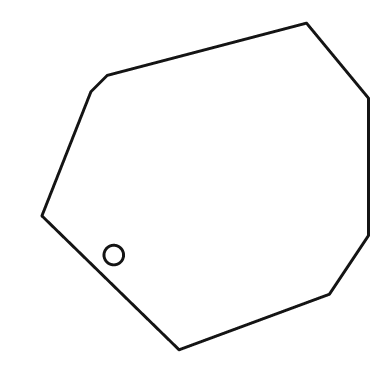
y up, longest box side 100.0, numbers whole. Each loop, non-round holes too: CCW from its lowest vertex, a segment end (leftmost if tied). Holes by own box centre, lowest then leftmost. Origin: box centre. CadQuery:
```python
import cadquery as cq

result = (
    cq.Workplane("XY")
    .moveTo(-8.0, -50.0)
    .lineTo(38.0, -33.0)
    .lineTo(50.0, -15.0)
    .lineTo(50.0, 27.0)
    .lineTo(31.0, 50.0)
    .lineTo(-30.0, 34.0)
    .lineTo(-35.0, 29.0)
    .lineTo(-50.0, -9.0)
    .close()
    .moveTo(-28.0, -21.0)
    .circle(3.0)
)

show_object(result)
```